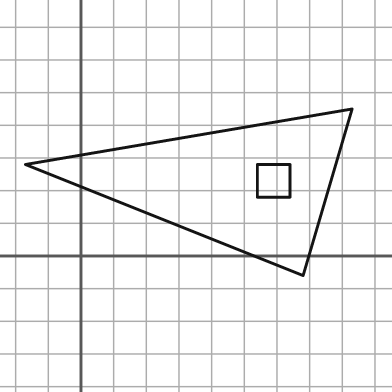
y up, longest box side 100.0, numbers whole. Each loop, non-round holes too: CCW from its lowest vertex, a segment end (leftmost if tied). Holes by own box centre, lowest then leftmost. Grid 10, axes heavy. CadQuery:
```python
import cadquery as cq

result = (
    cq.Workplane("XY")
    .moveTo(68.0, -6.0)
    .lineTo(83.0, 45.0)
    .lineTo(-17.0, 28.0)
    .close()
    .moveTo(54.0, 18.0)
    .lineTo(64.0, 18.0)
    .lineTo(64.0, 28.0)
    .lineTo(54.0, 28.0)
    .close()
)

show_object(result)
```